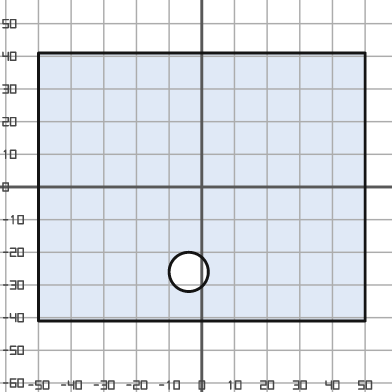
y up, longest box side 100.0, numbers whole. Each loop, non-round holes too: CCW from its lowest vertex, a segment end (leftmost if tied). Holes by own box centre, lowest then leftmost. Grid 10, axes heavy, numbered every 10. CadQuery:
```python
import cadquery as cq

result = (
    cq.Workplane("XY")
    .moveTo(-50.0, -41.0)
    .lineTo(50.0, -41.0)
    .lineTo(50.0, 41.0)
    .lineTo(-50.0, 41.0)
    .close()
    .moveTo(-4.0, -26.0)
    .circle(6.0)
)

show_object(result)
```